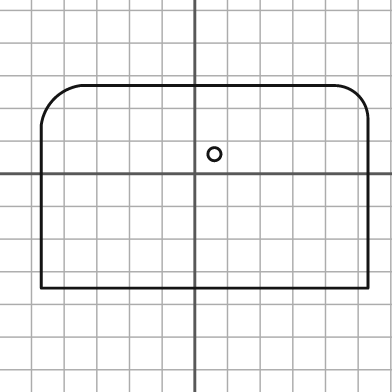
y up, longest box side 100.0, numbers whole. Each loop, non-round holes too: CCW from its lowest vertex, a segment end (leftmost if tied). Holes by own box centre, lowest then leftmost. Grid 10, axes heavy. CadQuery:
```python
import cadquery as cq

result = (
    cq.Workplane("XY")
    .moveTo(-47.0, -35.0)
    .lineTo(53.0, -35.0)
    .lineTo(53.0, 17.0)
    .threePointArc((50.0, 24.0), (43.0, 27.0))
    .lineTo(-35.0, 27.0)
    .threePointArc((-43.0, 23.0), (-47.0, 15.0))
    .close()
    .moveTo(6.0, 6.0)
    .circle(2.0)
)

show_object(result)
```